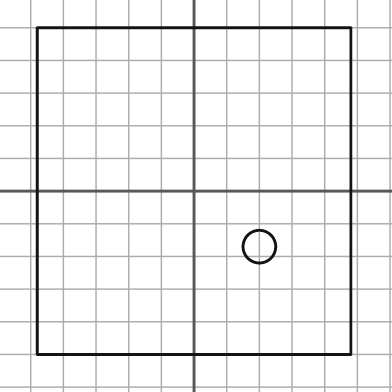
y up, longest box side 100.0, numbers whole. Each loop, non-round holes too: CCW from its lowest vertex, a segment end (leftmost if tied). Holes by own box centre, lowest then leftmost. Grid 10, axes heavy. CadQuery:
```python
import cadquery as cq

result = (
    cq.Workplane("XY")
    .moveTo(-48.0, -50.0)
    .lineTo(48.0, -50.0)
    .lineTo(48.0, 50.0)
    .lineTo(-48.0, 50.0)
    .close()
    .moveTo(20.0, -17.0)
    .circle(5.0)
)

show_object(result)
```